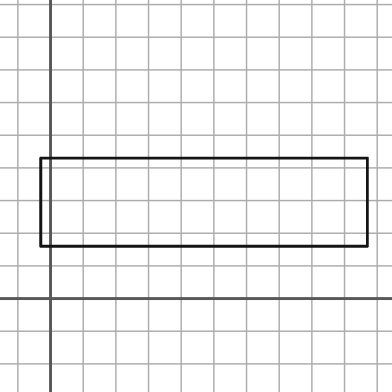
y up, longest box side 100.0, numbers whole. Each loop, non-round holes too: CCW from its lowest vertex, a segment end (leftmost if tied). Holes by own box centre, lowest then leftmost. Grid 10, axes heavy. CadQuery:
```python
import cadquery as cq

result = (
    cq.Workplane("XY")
    .moveTo(-3.0, 16.0)
    .lineTo(97.0, 16.0)
    .lineTo(97.0, 43.0)
    .lineTo(-3.0, 43.0)
    .close()
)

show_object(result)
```